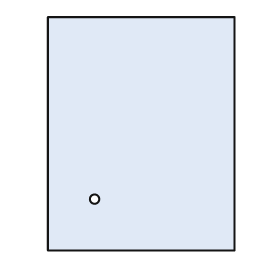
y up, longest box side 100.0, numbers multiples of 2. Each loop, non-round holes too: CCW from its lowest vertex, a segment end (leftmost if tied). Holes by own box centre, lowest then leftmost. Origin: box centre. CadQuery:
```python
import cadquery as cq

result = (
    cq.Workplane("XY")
    .moveTo(-40.0, -50.0)
    .lineTo(40.0, -50.0)
    .lineTo(40.0, 50.0)
    .lineTo(-40.0, 50.0)
    .close()
    .moveTo(-20.0, -28.0)
    .circle(2.0)
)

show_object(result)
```